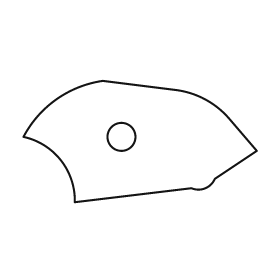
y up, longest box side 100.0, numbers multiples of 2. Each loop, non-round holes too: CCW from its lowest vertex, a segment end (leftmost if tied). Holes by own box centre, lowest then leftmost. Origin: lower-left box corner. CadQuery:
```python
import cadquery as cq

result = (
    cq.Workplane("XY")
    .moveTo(22.0, 0.0)
    .lineTo(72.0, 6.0)
    .threePointArc((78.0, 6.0), (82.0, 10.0))
    .lineTo(100.0, 22.0)
    .lineTo(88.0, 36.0)
    .threePointArc((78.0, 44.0), (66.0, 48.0))
    .lineTo(34.0, 52.0)
    .threePointArc((14.0, 44.0), (0.0, 28.0))
    .threePointArc((16.0, 18.0), (22.0, 0.0))
    .close()
    .moveTo(42.0, 28.0)
    .circle(6.0)
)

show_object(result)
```